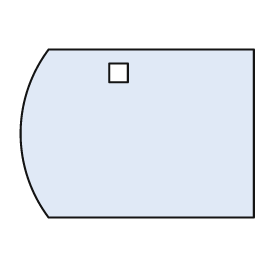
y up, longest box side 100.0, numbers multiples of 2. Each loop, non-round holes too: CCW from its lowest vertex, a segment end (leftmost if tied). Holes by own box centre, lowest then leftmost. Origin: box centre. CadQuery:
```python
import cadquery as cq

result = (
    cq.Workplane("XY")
    .moveTo(-38.0, -36.0)
    .lineTo(50.0, -36.0)
    .lineTo(50.0, 36.0)
    .lineTo(-38.0, 36.0)
    .threePointArc((-50.0, 0.0), (-38.0, -36.0))
    .close()
    .moveTo(-12.0, 22.0)
    .lineTo(-4.0, 22.0)
    .lineTo(-4.0, 30.0)
    .lineTo(-12.0, 30.0)
    .close()
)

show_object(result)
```